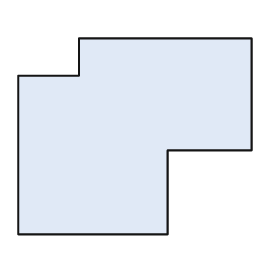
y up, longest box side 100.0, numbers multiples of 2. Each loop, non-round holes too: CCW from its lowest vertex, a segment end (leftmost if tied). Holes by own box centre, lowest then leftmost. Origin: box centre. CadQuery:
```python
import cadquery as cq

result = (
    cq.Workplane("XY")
    .moveTo(-50.0, -42.0)
    .lineTo(14.0, -42.0)
    .lineTo(14.0, -6.0)
    .lineTo(50.0, -6.0)
    .lineTo(50.0, 42.0)
    .lineTo(-24.0, 42.0)
    .lineTo(-24.0, 26.0)
    .lineTo(-50.0, 26.0)
    .close()
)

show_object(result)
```